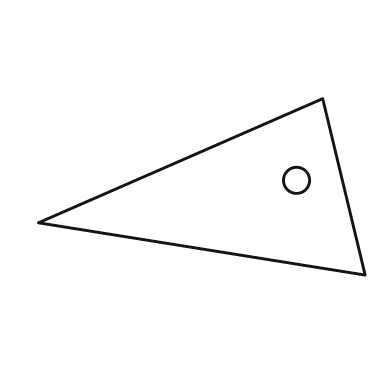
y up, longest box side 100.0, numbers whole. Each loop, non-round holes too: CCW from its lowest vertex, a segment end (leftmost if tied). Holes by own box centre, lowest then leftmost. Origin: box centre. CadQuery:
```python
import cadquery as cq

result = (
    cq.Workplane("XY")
    .moveTo(50.0, -27.0)
    .lineTo(37.0, 27.0)
    .lineTo(-50.0, -11.0)
    .close()
    .moveTo(29.0, 2.0)
    .circle(4.0)
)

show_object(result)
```